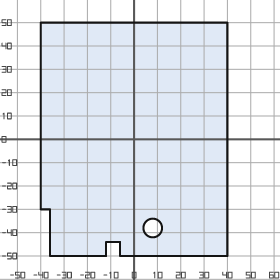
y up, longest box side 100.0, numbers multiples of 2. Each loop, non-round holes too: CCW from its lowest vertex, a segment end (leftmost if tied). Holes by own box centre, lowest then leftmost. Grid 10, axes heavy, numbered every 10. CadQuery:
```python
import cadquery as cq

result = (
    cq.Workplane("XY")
    .moveTo(-36.0, -50.0)
    .lineTo(-12.0, -50.0)
    .lineTo(-12.0, -44.0)
    .lineTo(-6.0, -44.0)
    .lineTo(-6.0, -50.0)
    .lineTo(40.0, -50.0)
    .lineTo(40.0, 50.0)
    .lineTo(-40.0, 50.0)
    .lineTo(-40.0, -30.0)
    .lineTo(-36.0, -30.0)
    .close()
    .moveTo(8.0, -38.0)
    .circle(4.0)
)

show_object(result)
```